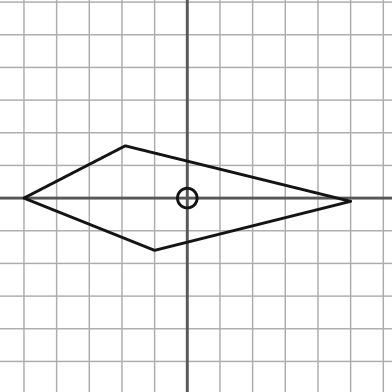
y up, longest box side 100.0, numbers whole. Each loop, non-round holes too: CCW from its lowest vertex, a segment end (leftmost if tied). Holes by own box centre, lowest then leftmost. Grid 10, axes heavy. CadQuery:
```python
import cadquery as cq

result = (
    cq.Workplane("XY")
    .moveTo(-10.0, -16.0)
    .lineTo(50.0, -1.0)
    .lineTo(-19.0, 16.0)
    .lineTo(-50.0, 0.0)
    .close()
    .moveTo(0.0, 0.0)
    .circle(3.0)
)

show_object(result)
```